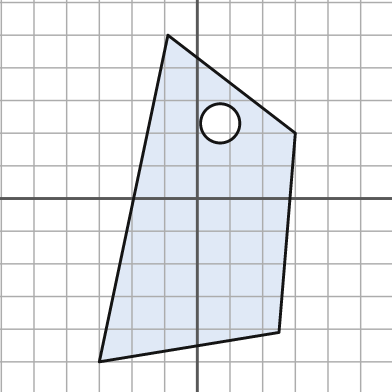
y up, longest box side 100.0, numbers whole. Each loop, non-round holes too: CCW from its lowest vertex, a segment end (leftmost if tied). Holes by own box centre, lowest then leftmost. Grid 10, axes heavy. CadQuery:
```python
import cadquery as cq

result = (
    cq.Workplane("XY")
    .moveTo(-30.0, -50.0)
    .lineTo(25.0, -41.0)
    .lineTo(30.0, 20.0)
    .lineTo(-9.0, 50.0)
    .close()
    .moveTo(7.0, 23.0)
    .circle(6.0)
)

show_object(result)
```